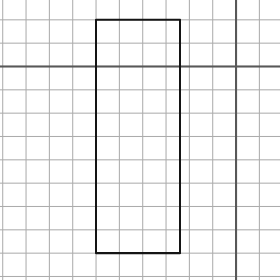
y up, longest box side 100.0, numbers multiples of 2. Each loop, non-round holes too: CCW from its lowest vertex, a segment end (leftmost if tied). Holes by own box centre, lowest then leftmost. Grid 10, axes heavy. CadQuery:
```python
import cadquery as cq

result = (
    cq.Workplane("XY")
    .moveTo(-60.0, -80.0)
    .lineTo(-24.0, -80.0)
    .lineTo(-24.0, 20.0)
    .lineTo(-60.0, 20.0)
    .close()
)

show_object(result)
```